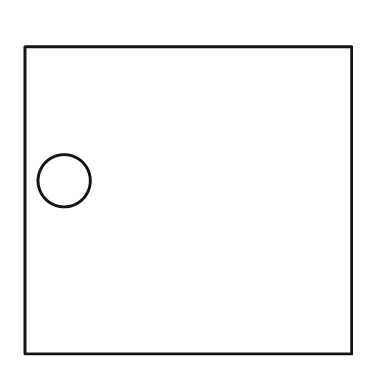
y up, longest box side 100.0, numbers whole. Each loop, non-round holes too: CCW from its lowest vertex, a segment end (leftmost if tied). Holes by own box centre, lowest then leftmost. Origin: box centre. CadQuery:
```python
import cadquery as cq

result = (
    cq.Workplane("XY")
    .moveTo(-50.0, -47.0)
    .lineTo(50.0, -47.0)
    .lineTo(50.0, 47.0)
    .lineTo(-50.0, 47.0)
    .close()
    .moveTo(-38.0, 6.0)
    .circle(8.0)
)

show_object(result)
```